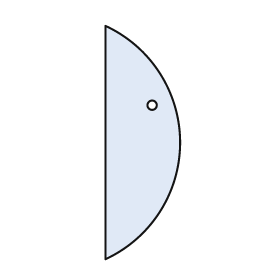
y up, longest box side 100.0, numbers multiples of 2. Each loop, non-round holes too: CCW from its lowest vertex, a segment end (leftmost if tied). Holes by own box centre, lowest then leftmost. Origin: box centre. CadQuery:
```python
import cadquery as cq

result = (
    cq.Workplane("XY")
    .moveTo(-16.0, -50.0)
    .threePointArc((16.0, 0.0), (-16.0, 50.0))
    .close()
    .moveTo(4.0, 16.0)
    .circle(2.0)
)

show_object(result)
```